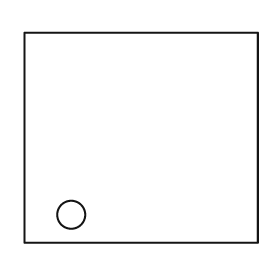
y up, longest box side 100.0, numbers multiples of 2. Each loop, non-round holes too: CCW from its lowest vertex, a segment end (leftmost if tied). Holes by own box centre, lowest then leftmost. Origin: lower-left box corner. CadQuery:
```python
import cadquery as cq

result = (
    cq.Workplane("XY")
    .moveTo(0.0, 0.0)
    .lineTo(100.0, 0.0)
    .lineTo(100.0, 90.0)
    .lineTo(0.0, 90.0)
    .close()
    .moveTo(20.0, 12.0)
    .circle(6.0)
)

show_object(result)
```